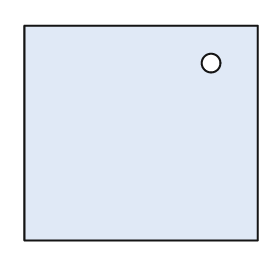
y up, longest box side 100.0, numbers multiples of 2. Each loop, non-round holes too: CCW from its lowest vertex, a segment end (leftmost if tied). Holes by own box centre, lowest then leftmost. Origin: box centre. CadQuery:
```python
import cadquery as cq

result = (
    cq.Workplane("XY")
    .moveTo(-50.0, -46.0)
    .lineTo(50.0, -46.0)
    .lineTo(50.0, 46.0)
    .lineTo(-50.0, 46.0)
    .close()
    .moveTo(30.0, 30.0)
    .circle(4.0)
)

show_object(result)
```